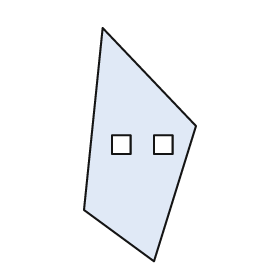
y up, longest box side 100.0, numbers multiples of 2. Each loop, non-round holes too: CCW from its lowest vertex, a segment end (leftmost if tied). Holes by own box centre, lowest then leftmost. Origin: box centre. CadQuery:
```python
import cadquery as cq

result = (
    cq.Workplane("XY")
    .moveTo(6.0, -50.0)
    .lineTo(24.0, 8.0)
    .lineTo(-16.0, 50.0)
    .lineTo(-24.0, -28.0)
    .close()
    .moveTo(-12.0, -4.0)
    .lineTo(-4.0, -4.0)
    .lineTo(-4.0, 4.0)
    .lineTo(-12.0, 4.0)
    .close()
    .moveTo(6.0, -4.0)
    .lineTo(14.0, -4.0)
    .lineTo(14.0, 4.0)
    .lineTo(6.0, 4.0)
    .close()
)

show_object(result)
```